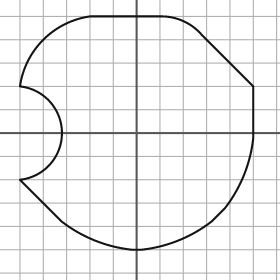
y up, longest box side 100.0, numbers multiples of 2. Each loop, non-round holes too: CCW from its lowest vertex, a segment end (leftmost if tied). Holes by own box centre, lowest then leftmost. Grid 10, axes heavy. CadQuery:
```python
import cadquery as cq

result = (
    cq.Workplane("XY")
    .moveTo(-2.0, -50.0)
    .lineTo(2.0, -50.0)
    .threePointArc((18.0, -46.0), (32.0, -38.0))
    .lineTo(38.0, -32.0)
    .threePointArc((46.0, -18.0), (50.0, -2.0))
    .lineTo(50.0, 20.0)
    .lineTo(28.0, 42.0)
    .threePointArc((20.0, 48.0), (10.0, 50.0))
    .lineTo(-20.0, 50.0)
    .threePointArc((-40.0, 40.0), (-50.0, 20.0))
    .threePointArc((-32.0, 0.0), (-50.0, -20.0))
    .lineTo(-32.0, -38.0)
    .threePointArc((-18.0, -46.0), (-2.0, -50.0))
    .close()
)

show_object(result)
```